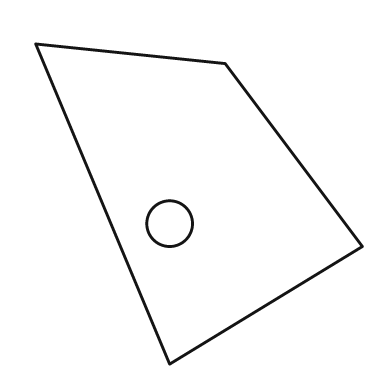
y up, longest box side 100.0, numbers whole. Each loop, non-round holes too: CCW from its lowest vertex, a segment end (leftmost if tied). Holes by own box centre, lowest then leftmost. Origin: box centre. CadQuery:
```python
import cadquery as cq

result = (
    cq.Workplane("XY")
    .moveTo(-9.0, -49.0)
    .lineTo(50.0, -13.0)
    .lineTo(8.0, 43.0)
    .lineTo(-50.0, 49.0)
    .close()
    .moveTo(-9.0, -6.0)
    .circle(7.0)
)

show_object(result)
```